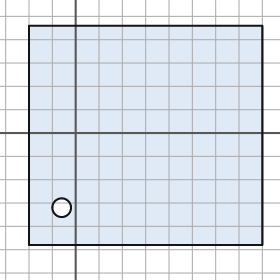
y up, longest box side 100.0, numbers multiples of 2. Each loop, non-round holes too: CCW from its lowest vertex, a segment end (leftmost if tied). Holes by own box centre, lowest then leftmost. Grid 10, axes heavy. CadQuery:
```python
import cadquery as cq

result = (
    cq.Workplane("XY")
    .moveTo(-20.0, -48.0)
    .lineTo(80.0, -48.0)
    .lineTo(80.0, 46.0)
    .lineTo(-20.0, 46.0)
    .close()
    .moveTo(-6.0, -32.0)
    .circle(4.0)
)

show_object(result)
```